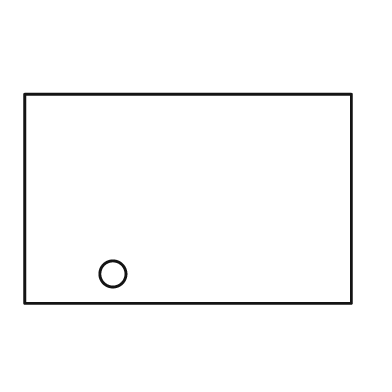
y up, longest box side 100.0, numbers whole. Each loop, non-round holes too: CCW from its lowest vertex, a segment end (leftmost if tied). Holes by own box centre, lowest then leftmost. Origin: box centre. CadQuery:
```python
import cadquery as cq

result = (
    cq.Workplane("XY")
    .moveTo(-50.0, -32.0)
    .lineTo(50.0, -32.0)
    .lineTo(50.0, 32.0)
    .lineTo(-50.0, 32.0)
    .close()
    .moveTo(-23.0, -23.0)
    .circle(4.0)
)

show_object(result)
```